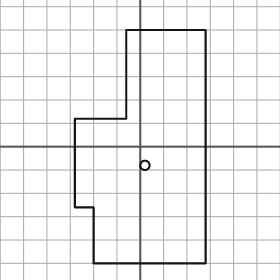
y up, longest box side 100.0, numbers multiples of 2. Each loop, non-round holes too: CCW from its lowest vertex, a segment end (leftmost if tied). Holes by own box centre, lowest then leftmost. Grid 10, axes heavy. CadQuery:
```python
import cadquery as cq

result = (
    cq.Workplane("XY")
    .moveTo(-20.0, -50.0)
    .lineTo(28.0, -50.0)
    .lineTo(28.0, 50.0)
    .lineTo(-6.0, 50.0)
    .lineTo(-6.0, 12.0)
    .lineTo(-28.0, 12.0)
    .lineTo(-28.0, -26.0)
    .lineTo(-20.0, -26.0)
    .close()
    .moveTo(2.0, -8.0)
    .circle(2.0)
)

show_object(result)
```